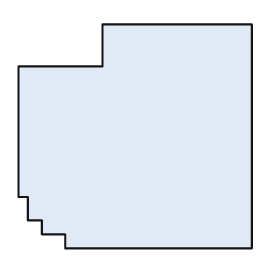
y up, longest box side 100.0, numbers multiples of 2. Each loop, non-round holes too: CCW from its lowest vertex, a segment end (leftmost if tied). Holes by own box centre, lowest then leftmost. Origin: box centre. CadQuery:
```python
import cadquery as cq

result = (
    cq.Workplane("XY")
    .moveTo(-30.0, -48.0)
    .lineTo(50.0, -48.0)
    .lineTo(50.0, 48.0)
    .lineTo(-14.0, 48.0)
    .lineTo(-14.0, 30.0)
    .lineTo(-50.0, 30.0)
    .lineTo(-50.0, -26.0)
    .lineTo(-46.0, -26.0)
    .lineTo(-46.0, -36.0)
    .lineTo(-40.0, -36.0)
    .lineTo(-40.0, -42.0)
    .lineTo(-30.0, -42.0)
    .close()
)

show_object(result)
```